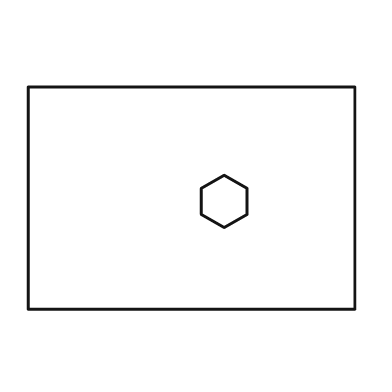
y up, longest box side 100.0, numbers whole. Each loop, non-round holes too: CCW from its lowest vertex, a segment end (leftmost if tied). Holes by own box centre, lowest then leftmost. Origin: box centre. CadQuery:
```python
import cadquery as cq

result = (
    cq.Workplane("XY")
    .moveTo(-50.0, -34.0)
    .lineTo(50.0, -34.0)
    .lineTo(50.0, 34.0)
    .lineTo(-50.0, 34.0)
    .close()
    .moveTo(10.0, -9.0)
    .lineTo(17.0, -5.0)
    .lineTo(17.0, 3.0)
    .lineTo(10.0, 7.0)
    .lineTo(3.0, 3.0)
    .lineTo(3.0, -5.0)
    .close()
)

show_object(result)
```